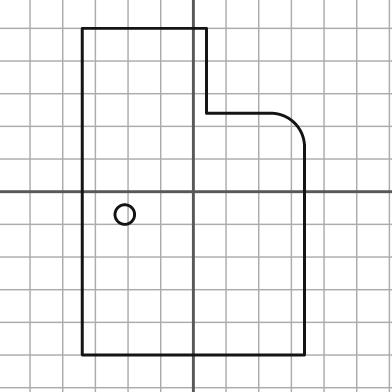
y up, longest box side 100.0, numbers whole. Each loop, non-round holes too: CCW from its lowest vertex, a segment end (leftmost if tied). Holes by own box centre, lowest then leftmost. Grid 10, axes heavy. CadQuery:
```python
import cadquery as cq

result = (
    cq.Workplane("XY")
    .moveTo(-34.0, -50.0)
    .lineTo(34.0, -50.0)
    .lineTo(34.0, 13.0)
    .threePointArc((31.0, 21.0), (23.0, 24.0))
    .lineTo(4.0, 24.0)
    .lineTo(4.0, 50.0)
    .lineTo(-34.0, 50.0)
    .close()
    .moveTo(-21.0, -7.0)
    .circle(3.0)
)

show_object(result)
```